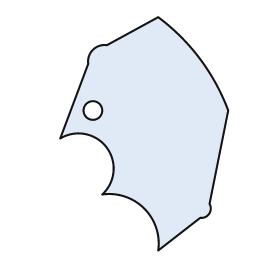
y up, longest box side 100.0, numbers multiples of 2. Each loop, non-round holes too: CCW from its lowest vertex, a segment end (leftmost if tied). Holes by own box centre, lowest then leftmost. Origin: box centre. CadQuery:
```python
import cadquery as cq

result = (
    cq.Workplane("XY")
    .moveTo(6.0, -50.0)
    .lineTo(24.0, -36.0)
    .threePointArc((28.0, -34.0), (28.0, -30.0))
    .lineTo(36.0, 10.0)
    .threePointArc((24.0, 32.0), (6.0, 50.0))
    .lineTo(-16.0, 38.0)
    .threePointArc((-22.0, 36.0), (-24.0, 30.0))
    .lineTo(-36.0, -2.0)
    .threePointArc((-16.0, -6.0), (-18.0, -26.0))
    .threePointArc((0.0, -32.0), (6.0, -50.0))
    .close()
    .moveTo(-22.0, 10.0)
    .circle(4.0)
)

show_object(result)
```